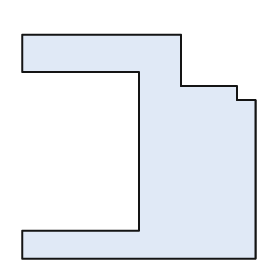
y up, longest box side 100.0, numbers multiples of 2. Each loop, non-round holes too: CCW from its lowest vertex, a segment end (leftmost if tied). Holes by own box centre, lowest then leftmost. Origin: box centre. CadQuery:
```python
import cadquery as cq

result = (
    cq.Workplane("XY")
    .moveTo(-50.0, -48.0)
    .lineTo(50.0, -48.0)
    .lineTo(50.0, 20.0)
    .lineTo(42.0, 20.0)
    .lineTo(42.0, 26.0)
    .lineTo(18.0, 26.0)
    .lineTo(18.0, 48.0)
    .lineTo(-50.0, 48.0)
    .lineTo(-50.0, 32.0)
    .lineTo(0.0, 32.0)
    .lineTo(0.0, -36.0)
    .lineTo(-50.0, -36.0)
    .close()
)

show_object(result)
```